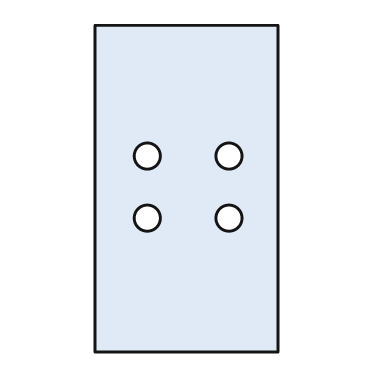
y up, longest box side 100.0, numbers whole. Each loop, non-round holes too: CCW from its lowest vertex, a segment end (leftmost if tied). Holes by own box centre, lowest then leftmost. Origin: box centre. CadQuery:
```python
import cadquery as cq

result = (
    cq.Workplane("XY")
    .moveTo(-28.0, -50.0)
    .lineTo(28.0, -50.0)
    .lineTo(28.0, 50.0)
    .lineTo(-28.0, 50.0)
    .close()
    .moveTo(-12.0, -9.0)
    .circle(4.0)
    .moveTo(13.0, -9.0)
    .circle(4.0)
    .moveTo(-12.0, 10.0)
    .circle(4.0)
    .moveTo(13.0, 10.0)
    .circle(4.0)
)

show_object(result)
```